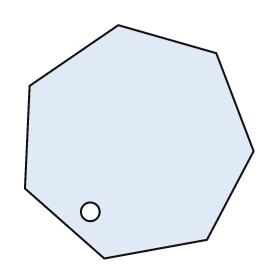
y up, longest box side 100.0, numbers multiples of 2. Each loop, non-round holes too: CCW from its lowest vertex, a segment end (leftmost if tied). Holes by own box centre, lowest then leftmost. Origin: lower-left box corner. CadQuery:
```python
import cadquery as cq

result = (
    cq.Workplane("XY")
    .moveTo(34.0, 0.0)
    .lineTo(78.0, 8.0)
    .lineTo(98.0, 46.0)
    .lineTo(82.0, 88.0)
    .lineTo(40.0, 100.0)
    .lineTo(2.0, 74.0)
    .lineTo(0.0, 30.0)
    .close()
    .moveTo(28.0, 20.0)
    .circle(4.0)
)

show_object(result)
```